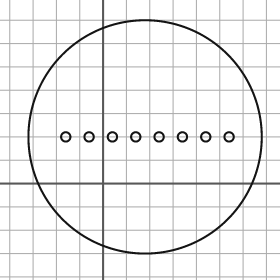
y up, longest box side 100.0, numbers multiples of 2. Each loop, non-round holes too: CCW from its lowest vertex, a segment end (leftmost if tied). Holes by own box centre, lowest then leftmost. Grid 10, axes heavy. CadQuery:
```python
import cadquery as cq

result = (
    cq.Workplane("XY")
    .moveTo(18.0, 20.0)
    .circle(50.0)
    .moveTo(-16.0, 20.0)
    .circle(2.0)
    .moveTo(-6.0, 20.0)
    .circle(2.0)
    .moveTo(4.0, 20.0)
    .circle(2.0)
    .moveTo(14.0, 20.0)
    .circle(2.0)
    .moveTo(24.0, 20.0)
    .circle(2.0)
    .moveTo(34.0, 20.0)
    .circle(2.0)
    .moveTo(44.0, 20.0)
    .circle(2.0)
    .moveTo(54.0, 20.0)
    .circle(2.0)
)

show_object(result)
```